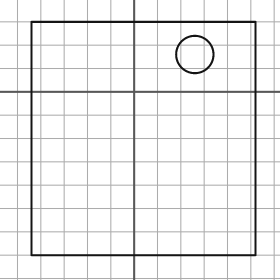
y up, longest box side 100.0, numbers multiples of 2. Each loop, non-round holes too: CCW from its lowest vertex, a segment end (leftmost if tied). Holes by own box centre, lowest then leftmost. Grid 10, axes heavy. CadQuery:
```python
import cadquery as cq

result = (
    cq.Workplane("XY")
    .moveTo(-44.0, -70.0)
    .lineTo(52.0, -70.0)
    .lineTo(52.0, 30.0)
    .lineTo(-44.0, 30.0)
    .close()
    .moveTo(26.0, 16.0)
    .circle(8.0)
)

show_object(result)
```